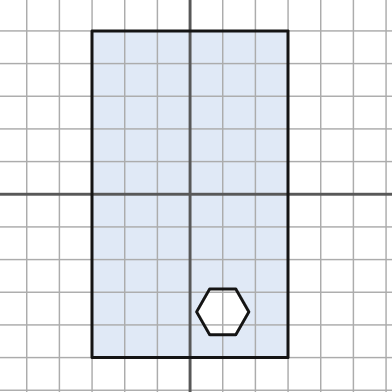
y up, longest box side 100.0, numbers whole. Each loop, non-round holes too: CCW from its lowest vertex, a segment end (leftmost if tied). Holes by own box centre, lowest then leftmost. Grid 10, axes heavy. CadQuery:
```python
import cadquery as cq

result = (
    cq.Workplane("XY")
    .moveTo(-30.0, -50.0)
    .lineTo(30.0, -50.0)
    .lineTo(30.0, 50.0)
    .lineTo(-30.0, 50.0)
    .close()
    .moveTo(6.0, -43.0)
    .lineTo(14.0, -43.0)
    .lineTo(18.0, -36.0)
    .lineTo(14.0, -29.0)
    .lineTo(6.0, -29.0)
    .lineTo(2.0, -36.0)
    .close()
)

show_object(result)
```